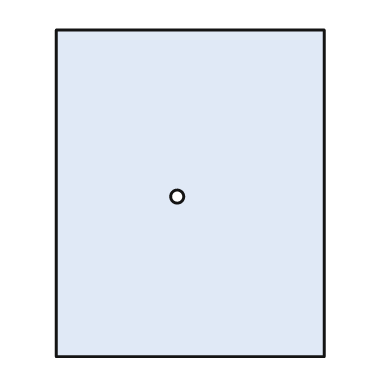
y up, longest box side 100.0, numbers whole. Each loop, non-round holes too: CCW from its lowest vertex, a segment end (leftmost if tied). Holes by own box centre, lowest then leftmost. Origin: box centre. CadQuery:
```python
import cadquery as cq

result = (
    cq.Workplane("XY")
    .moveTo(-41.0, -50.0)
    .lineTo(41.0, -50.0)
    .lineTo(41.0, 50.0)
    .lineTo(-41.0, 50.0)
    .close()
    .moveTo(-4.0, -1.0)
    .circle(2.0)
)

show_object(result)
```